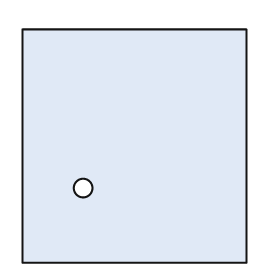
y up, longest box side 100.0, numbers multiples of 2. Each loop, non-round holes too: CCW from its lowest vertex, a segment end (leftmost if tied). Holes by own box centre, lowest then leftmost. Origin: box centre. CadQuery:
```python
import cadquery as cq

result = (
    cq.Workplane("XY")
    .moveTo(-48.0, -50.0)
    .lineTo(48.0, -50.0)
    .lineTo(48.0, 50.0)
    .lineTo(-48.0, 50.0)
    .close()
    .moveTo(-22.0, -18.0)
    .circle(4.0)
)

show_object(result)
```